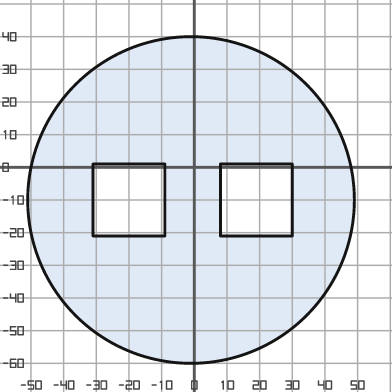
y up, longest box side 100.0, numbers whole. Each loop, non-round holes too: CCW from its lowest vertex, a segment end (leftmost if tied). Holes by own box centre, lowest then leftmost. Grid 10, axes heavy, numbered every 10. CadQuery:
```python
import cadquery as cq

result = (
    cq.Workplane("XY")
    .moveTo(-1.0, -10.0)
    .circle(50.0)
    .moveTo(-31.0, -21.0)
    .lineTo(-9.0, -21.0)
    .lineTo(-9.0, 1.0)
    .lineTo(-31.0, 1.0)
    .close()
    .moveTo(8.0, -21.0)
    .lineTo(30.0, -21.0)
    .lineTo(30.0, 1.0)
    .lineTo(8.0, 1.0)
    .close()
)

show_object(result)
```